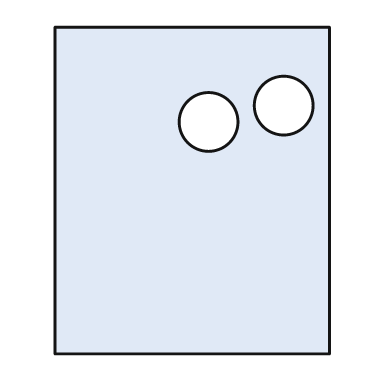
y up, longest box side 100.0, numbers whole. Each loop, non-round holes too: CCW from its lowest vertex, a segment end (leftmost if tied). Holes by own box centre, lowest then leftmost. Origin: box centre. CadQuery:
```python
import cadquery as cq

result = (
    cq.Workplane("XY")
    .moveTo(-42.0, -50.0)
    .lineTo(42.0, -50.0)
    .lineTo(42.0, 50.0)
    .lineTo(-42.0, 50.0)
    .close()
    .moveTo(5.0, 21.0)
    .circle(9.0)
    .moveTo(28.0, 26.0)
    .circle(9.0)
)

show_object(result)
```